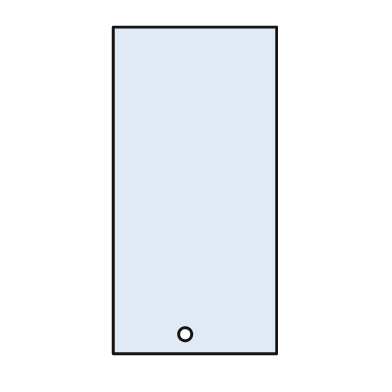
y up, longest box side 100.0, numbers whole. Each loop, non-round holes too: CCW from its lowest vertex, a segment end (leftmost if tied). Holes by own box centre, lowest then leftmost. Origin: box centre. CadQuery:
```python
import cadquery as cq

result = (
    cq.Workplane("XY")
    .moveTo(-25.0, -50.0)
    .lineTo(25.0, -50.0)
    .lineTo(25.0, 50.0)
    .lineTo(-25.0, 50.0)
    .close()
    .moveTo(-3.0, -44.0)
    .circle(2.0)
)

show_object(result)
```